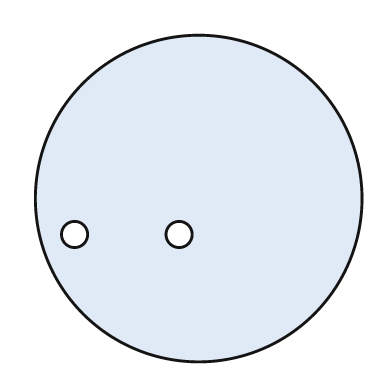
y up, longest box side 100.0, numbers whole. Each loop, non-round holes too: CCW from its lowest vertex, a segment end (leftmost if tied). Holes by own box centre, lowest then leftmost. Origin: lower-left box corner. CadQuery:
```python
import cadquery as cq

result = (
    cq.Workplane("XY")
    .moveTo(50.0, 50.0)
    .circle(50.0)
    .moveTo(12.0, 39.0)
    .circle(4.0)
    .moveTo(44.0, 39.0)
    .circle(4.0)
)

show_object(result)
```